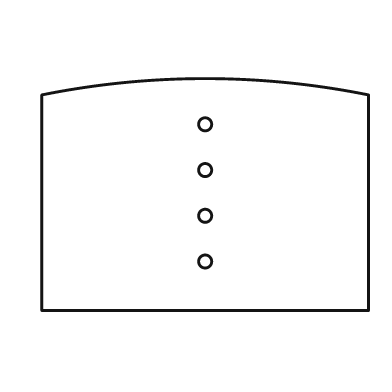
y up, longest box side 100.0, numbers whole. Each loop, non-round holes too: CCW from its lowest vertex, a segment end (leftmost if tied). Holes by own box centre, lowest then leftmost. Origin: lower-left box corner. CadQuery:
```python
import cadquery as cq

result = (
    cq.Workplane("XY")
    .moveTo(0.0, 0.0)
    .lineTo(100.0, 0.0)
    .lineTo(100.0, 66.0)
    .threePointArc((50.0, 71.0), (0.0, 66.0))
    .close()
    .moveTo(50.0, 15.0)
    .circle(2.0)
    .moveTo(50.0, 29.0)
    .circle(2.0)
    .moveTo(50.0, 43.0)
    .circle(2.0)
    .moveTo(50.0, 57.0)
    .circle(2.0)
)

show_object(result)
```